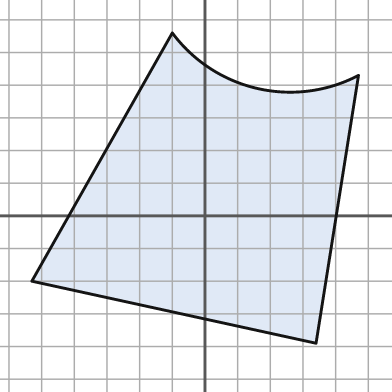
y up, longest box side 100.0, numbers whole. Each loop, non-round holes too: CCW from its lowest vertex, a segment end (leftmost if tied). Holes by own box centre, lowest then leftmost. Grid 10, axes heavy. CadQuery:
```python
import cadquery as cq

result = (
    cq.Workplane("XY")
    .moveTo(34.0, -39.0)
    .lineTo(47.0, 43.0)
    .threePointArc((16.0, 39.0), (-10.0, 56.0))
    .lineTo(-53.0, -20.0)
    .close()
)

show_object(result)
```